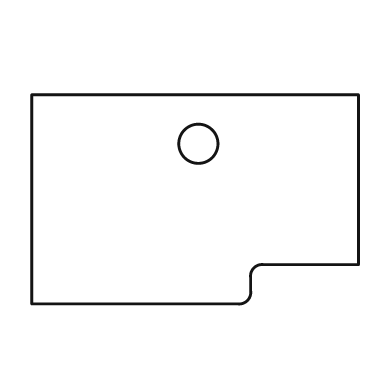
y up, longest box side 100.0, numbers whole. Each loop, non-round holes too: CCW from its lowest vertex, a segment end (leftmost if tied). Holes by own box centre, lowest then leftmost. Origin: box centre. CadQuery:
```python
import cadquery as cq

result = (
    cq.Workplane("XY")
    .moveTo(-50.0, -32.0)
    .lineTo(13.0, -32.0)
    .threePointArc((16.0, -31.0), (17.0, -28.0))
    .lineTo(17.0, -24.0)
    .threePointArc((18.0, -21.0), (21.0, -20.0))
    .lineTo(50.0, -20.0)
    .lineTo(50.0, 32.0)
    .lineTo(-50.0, 32.0)
    .close()
    .moveTo(1.0, 17.0)
    .circle(6.0)
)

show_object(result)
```